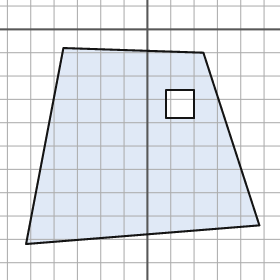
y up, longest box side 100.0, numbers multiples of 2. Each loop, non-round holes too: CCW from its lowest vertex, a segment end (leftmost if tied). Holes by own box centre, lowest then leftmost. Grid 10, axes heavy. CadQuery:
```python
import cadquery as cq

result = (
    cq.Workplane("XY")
    .moveTo(-52.0, -92.0)
    .lineTo(48.0, -84.0)
    .lineTo(24.0, -10.0)
    .lineTo(-36.0, -8.0)
    .close()
    .moveTo(8.0, -38.0)
    .lineTo(20.0, -38.0)
    .lineTo(20.0, -26.0)
    .lineTo(8.0, -26.0)
    .close()
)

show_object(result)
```